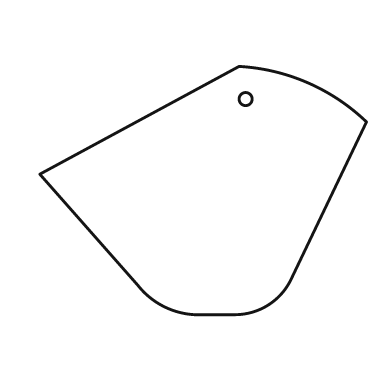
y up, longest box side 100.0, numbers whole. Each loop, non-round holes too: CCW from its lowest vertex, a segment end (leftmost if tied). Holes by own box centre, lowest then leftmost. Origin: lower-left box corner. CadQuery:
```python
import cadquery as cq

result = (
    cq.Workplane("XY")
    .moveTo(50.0, 0.0)
    .lineTo(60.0, 0.0)
    .threePointArc((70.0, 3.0), (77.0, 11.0))
    .lineTo(100.0, 59.0)
    .threePointArc((82.0, 71.0), (61.0, 76.0))
    .lineTo(0.0, 43.0)
    .lineTo(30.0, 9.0)
    .threePointArc((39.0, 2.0), (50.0, 0.0))
    .close()
    .moveTo(63.0, 66.0)
    .circle(2.0)
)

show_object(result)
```